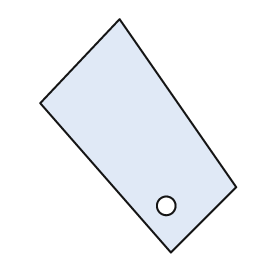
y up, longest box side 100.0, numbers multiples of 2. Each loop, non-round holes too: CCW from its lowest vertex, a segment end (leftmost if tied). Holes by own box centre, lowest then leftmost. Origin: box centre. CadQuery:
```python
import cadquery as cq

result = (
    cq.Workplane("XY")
    .moveTo(14.0, -50.0)
    .lineTo(42.0, -22.0)
    .lineTo(-8.0, 50.0)
    .lineTo(-42.0, 14.0)
    .close()
    .moveTo(12.0, -30.0)
    .circle(4.0)
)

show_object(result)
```